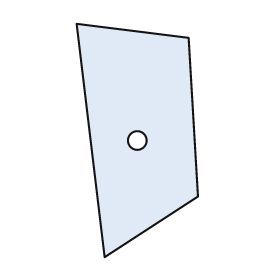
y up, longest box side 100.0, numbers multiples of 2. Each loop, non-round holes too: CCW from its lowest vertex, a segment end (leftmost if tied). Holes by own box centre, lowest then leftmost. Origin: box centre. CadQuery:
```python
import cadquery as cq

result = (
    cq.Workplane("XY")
    .moveTo(-14.0, -50.0)
    .lineTo(26.0, -24.0)
    .lineTo(22.0, 44.0)
    .lineTo(-26.0, 50.0)
    .close()
    .moveTo(0.0, 0.0)
    .circle(4.0)
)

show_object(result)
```